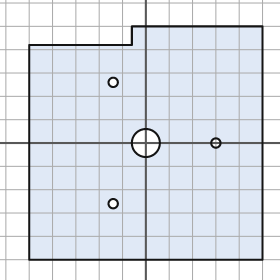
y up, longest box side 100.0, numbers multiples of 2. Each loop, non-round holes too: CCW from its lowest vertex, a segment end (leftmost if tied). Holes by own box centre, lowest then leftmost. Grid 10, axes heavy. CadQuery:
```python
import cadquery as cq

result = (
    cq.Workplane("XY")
    .moveTo(-50.0, -50.0)
    .lineTo(50.0, -50.0)
    .lineTo(50.0, 50.0)
    .lineTo(-6.0, 50.0)
    .lineTo(-6.0, 42.0)
    .lineTo(-50.0, 42.0)
    .close()
    .moveTo(-14.0, -26.0)
    .circle(2.0)
    .moveTo(0.0, 0.0)
    .circle(6.0)
    .moveTo(30.0, 0.0)
    .circle(2.0)
    .moveTo(-14.0, 26.0)
    .circle(2.0)
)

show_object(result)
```